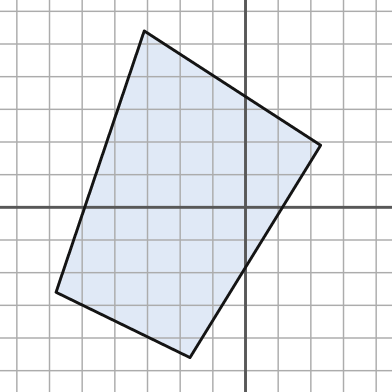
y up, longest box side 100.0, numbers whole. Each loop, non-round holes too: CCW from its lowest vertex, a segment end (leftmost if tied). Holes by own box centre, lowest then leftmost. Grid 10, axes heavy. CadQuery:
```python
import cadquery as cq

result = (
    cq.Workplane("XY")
    .moveTo(-17.0, -46.0)
    .lineTo(23.0, 19.0)
    .lineTo(-31.0, 54.0)
    .lineTo(-58.0, -26.0)
    .close()
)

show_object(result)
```